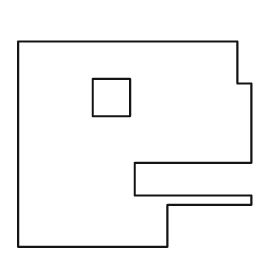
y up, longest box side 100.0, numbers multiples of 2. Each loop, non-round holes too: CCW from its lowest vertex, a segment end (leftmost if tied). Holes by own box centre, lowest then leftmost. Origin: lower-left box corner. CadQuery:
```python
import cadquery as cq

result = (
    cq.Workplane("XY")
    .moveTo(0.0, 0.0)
    .lineTo(64.0, 0.0)
    .lineTo(64.0, 18.0)
    .lineTo(100.0, 18.0)
    .lineTo(100.0, 22.0)
    .lineTo(50.0, 22.0)
    .lineTo(50.0, 36.0)
    .lineTo(100.0, 36.0)
    .lineTo(100.0, 70.0)
    .lineTo(94.0, 70.0)
    .lineTo(94.0, 88.0)
    .lineTo(0.0, 88.0)
    .close()
    .moveTo(32.0, 56.0)
    .lineTo(48.0, 56.0)
    .lineTo(48.0, 72.0)
    .lineTo(32.0, 72.0)
    .close()
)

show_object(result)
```